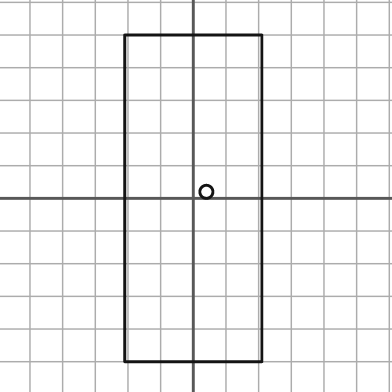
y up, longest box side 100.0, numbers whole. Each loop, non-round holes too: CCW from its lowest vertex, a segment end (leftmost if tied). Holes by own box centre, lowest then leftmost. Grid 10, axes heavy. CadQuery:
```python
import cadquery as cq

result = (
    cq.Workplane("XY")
    .moveTo(-21.0, -50.0)
    .lineTo(21.0, -50.0)
    .lineTo(21.0, 50.0)
    .lineTo(-21.0, 50.0)
    .close()
    .moveTo(4.0, 2.0)
    .circle(2.0)
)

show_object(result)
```